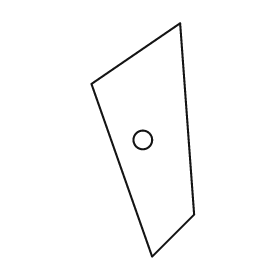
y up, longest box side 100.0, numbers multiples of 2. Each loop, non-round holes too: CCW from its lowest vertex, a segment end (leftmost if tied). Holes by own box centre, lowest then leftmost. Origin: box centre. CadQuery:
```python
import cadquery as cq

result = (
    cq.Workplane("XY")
    .moveTo(4.0, -50.0)
    .lineTo(22.0, -32.0)
    .lineTo(16.0, 50.0)
    .lineTo(-22.0, 24.0)
    .close()
    .moveTo(0.0, 0.0)
    .circle(4.0)
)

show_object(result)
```